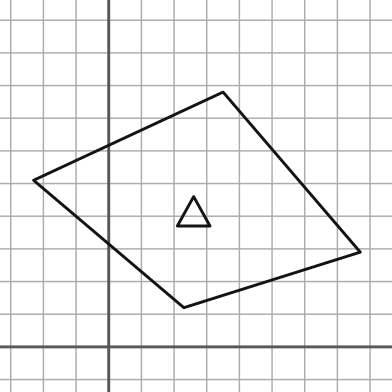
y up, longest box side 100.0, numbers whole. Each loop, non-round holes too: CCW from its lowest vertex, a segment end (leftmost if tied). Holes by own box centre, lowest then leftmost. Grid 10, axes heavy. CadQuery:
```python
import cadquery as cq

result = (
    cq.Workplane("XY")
    .moveTo(23.0, 12.0)
    .lineTo(77.0, 29.0)
    .lineTo(35.0, 78.0)
    .lineTo(-23.0, 51.0)
    .close()
    .moveTo(21.0, 37.0)
    .lineTo(31.0, 37.0)
    .lineTo(26.0, 46.0)
    .close()
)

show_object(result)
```